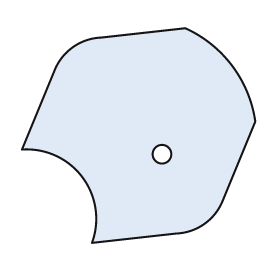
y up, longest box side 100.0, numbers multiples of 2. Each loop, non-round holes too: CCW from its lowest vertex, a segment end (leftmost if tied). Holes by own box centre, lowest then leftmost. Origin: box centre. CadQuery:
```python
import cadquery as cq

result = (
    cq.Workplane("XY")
    .moveTo(-20.0, -46.0)
    .lineTo(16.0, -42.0)
    .threePointArc((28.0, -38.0), (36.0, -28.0))
    .lineTo(50.0, 6.0)
    .threePointArc((40.0, 30.0), (20.0, 46.0))
    .lineTo(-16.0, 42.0)
    .threePointArc((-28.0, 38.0), (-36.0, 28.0))
    .lineTo(-50.0, -6.0)
    .threePointArc((-24.0, -18.0), (-20.0, -46.0))
    .close()
    .moveTo(10.0, -8.0)
    .circle(4.0)
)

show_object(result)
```